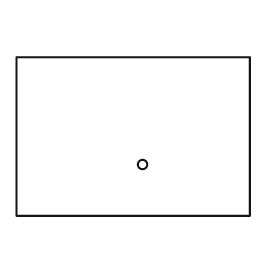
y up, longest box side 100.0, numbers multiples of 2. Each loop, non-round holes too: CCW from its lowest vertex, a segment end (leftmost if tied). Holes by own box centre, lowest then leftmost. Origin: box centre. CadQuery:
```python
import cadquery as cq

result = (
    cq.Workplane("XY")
    .moveTo(-50.0, -34.0)
    .lineTo(50.0, -34.0)
    .lineTo(50.0, 34.0)
    .lineTo(-50.0, 34.0)
    .close()
    .moveTo(4.0, -12.0)
    .circle(2.0)
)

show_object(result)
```